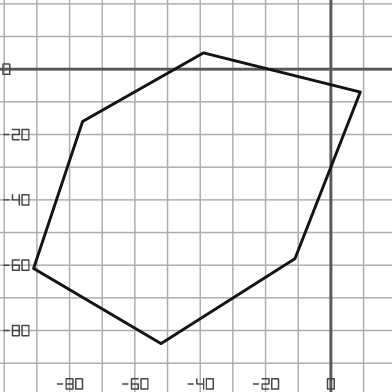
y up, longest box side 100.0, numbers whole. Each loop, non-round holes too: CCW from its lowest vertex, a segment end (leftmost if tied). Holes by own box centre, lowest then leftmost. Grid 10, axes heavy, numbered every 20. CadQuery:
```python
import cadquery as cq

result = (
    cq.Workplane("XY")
    .moveTo(-52.0, -84.0)
    .lineTo(-11.0, -58.0)
    .lineTo(9.0, -7.0)
    .lineTo(-39.0, 5.0)
    .lineTo(-76.0, -16.0)
    .lineTo(-91.0, -61.0)
    .close()
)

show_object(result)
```